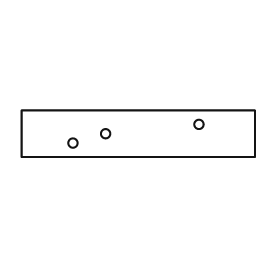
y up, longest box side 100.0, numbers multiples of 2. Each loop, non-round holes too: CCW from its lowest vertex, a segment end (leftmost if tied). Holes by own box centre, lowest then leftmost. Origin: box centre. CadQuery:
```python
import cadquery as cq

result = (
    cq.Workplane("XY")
    .moveTo(-50.0, -10.0)
    .lineTo(50.0, -10.0)
    .lineTo(50.0, 10.0)
    .lineTo(-50.0, 10.0)
    .close()
    .moveTo(-28.0, -4.0)
    .circle(2.0)
    .moveTo(-14.0, 0.0)
    .circle(2.0)
    .moveTo(26.0, 4.0)
    .circle(2.0)
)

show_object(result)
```